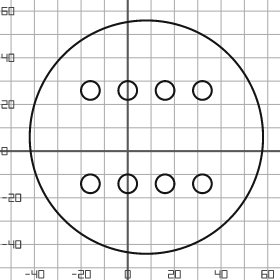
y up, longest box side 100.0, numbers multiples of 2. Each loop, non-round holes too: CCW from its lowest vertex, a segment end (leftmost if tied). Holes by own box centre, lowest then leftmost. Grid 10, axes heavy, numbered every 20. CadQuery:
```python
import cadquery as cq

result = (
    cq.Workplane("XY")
    .moveTo(8.0, 6.0)
    .circle(50.0)
    .moveTo(-16.0, -14.0)
    .circle(4.0)
    .moveTo(0.0, -14.0)
    .circle(4.0)
    .moveTo(16.0, -14.0)
    .circle(4.0)
    .moveTo(32.0, -14.0)
    .circle(4.0)
    .moveTo(-16.0, 26.0)
    .circle(4.0)
    .moveTo(0.0, 26.0)
    .circle(4.0)
    .moveTo(16.0, 26.0)
    .circle(4.0)
    .moveTo(32.0, 26.0)
    .circle(4.0)
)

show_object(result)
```